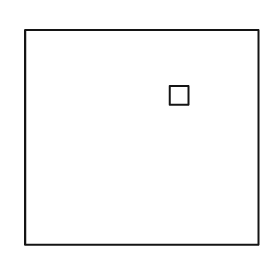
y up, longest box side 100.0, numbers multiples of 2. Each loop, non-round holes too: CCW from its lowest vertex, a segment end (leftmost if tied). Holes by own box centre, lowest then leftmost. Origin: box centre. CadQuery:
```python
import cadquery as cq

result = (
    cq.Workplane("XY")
    .moveTo(-50.0, -46.0)
    .lineTo(50.0, -46.0)
    .lineTo(50.0, 46.0)
    .lineTo(-50.0, 46.0)
    .close()
    .moveTo(12.0, 14.0)
    .lineTo(20.0, 14.0)
    .lineTo(20.0, 22.0)
    .lineTo(12.0, 22.0)
    .close()
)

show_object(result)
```